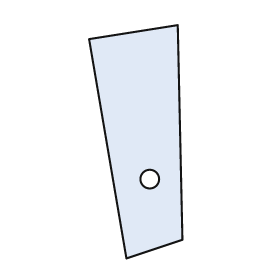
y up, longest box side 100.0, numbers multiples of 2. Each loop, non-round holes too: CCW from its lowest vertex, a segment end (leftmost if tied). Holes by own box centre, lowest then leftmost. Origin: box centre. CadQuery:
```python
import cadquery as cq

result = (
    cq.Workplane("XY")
    .moveTo(-4.0, -50.0)
    .lineTo(20.0, -42.0)
    .lineTo(18.0, 50.0)
    .lineTo(-20.0, 44.0)
    .close()
    .moveTo(6.0, -16.0)
    .circle(4.0)
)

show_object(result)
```